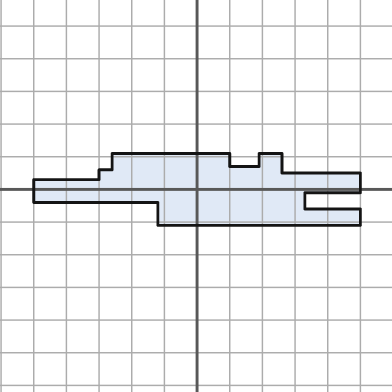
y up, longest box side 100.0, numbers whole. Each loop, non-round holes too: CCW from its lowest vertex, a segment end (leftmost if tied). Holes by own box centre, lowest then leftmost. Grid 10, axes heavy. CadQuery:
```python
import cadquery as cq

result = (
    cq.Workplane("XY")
    .moveTo(-12.0, -11.0)
    .lineTo(50.0, -11.0)
    .lineTo(50.0, -6.0)
    .lineTo(33.0, -6.0)
    .lineTo(33.0, -1.0)
    .lineTo(50.0, -1.0)
    .lineTo(50.0, 5.0)
    .lineTo(26.0, 5.0)
    .lineTo(26.0, 11.0)
    .lineTo(19.0, 11.0)
    .lineTo(19.0, 7.0)
    .lineTo(10.0, 7.0)
    .lineTo(10.0, 11.0)
    .lineTo(-26.0, 11.0)
    .lineTo(-26.0, 6.0)
    .lineTo(-30.0, 6.0)
    .lineTo(-30.0, 3.0)
    .lineTo(-50.0, 3.0)
    .lineTo(-50.0, -4.0)
    .lineTo(-12.0, -4.0)
    .close()
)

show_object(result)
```